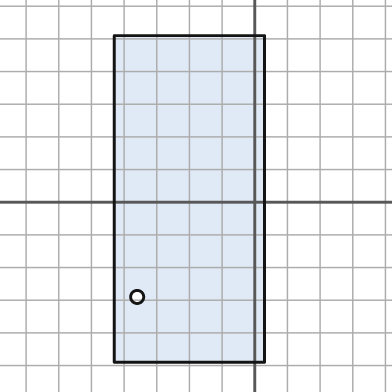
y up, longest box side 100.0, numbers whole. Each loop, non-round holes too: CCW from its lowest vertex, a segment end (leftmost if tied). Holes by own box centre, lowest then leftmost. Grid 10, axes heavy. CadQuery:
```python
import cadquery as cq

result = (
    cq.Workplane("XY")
    .moveTo(-43.0, -49.0)
    .lineTo(3.0, -49.0)
    .lineTo(3.0, 51.0)
    .lineTo(-43.0, 51.0)
    .close()
    .moveTo(-36.0, -29.0)
    .circle(2.0)
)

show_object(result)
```